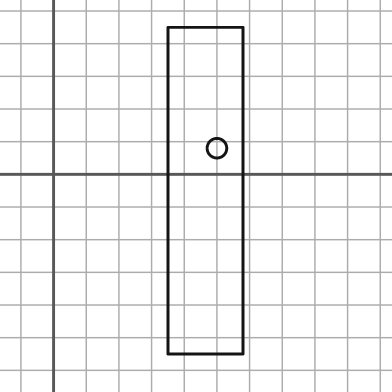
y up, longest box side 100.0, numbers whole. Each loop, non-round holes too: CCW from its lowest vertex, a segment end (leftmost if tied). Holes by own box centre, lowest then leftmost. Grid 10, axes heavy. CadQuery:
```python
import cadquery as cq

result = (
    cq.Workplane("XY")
    .moveTo(35.0, -55.0)
    .lineTo(58.0, -55.0)
    .lineTo(58.0, 45.0)
    .lineTo(35.0, 45.0)
    .close()
    .moveTo(50.0, 8.0)
    .circle(3.0)
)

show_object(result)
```